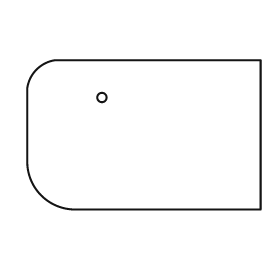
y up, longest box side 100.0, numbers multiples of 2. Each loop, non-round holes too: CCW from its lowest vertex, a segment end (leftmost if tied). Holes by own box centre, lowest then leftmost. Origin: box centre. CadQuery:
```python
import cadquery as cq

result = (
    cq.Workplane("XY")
    .moveTo(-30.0, -32.0)
    .lineTo(50.0, -32.0)
    .lineTo(50.0, 32.0)
    .lineTo(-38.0, 32.0)
    .threePointArc((-46.0, 28.0), (-50.0, 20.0))
    .lineTo(-50.0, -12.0)
    .threePointArc((-44.0, -26.0), (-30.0, -32.0))
    .close()
    .moveTo(-18.0, 16.0)
    .circle(2.0)
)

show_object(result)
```